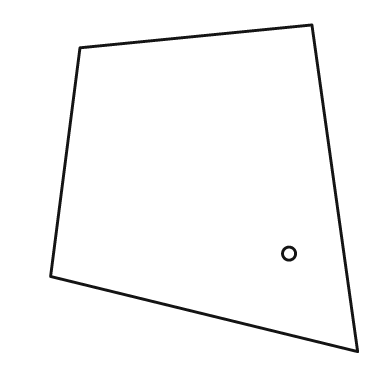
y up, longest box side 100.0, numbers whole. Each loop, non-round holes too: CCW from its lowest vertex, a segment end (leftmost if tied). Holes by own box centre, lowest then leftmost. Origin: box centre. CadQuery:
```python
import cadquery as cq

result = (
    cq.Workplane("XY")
    .moveTo(47.0, -50.0)
    .lineTo(33.0, 50.0)
    .lineTo(-38.0, 43.0)
    .lineTo(-47.0, -27.0)
    .close()
    .moveTo(26.0, -20.0)
    .circle(2.0)
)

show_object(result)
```